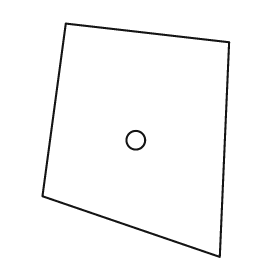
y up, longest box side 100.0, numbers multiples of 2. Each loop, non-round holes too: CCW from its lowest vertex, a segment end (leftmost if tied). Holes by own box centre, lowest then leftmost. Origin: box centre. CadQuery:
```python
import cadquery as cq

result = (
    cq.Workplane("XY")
    .moveTo(36.0, -50.0)
    .lineTo(40.0, 42.0)
    .lineTo(-30.0, 50.0)
    .lineTo(-40.0, -24.0)
    .close()
    .moveTo(0.0, 0.0)
    .circle(4.0)
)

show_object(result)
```